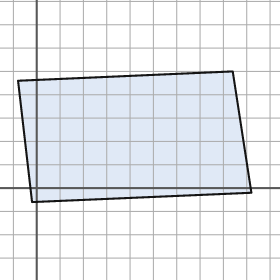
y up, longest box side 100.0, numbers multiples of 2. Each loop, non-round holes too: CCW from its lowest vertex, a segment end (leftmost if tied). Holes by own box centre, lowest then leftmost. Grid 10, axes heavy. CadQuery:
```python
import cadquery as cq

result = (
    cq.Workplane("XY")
    .moveTo(-2.0, -6.0)
    .lineTo(92.0, -2.0)
    .lineTo(84.0, 50.0)
    .lineTo(-8.0, 46.0)
    .close()
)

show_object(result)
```